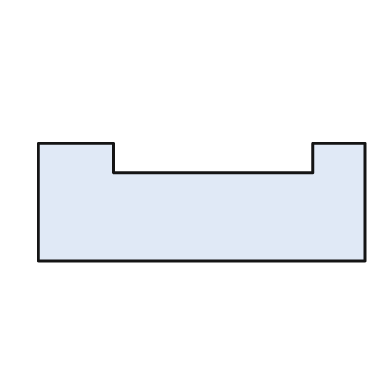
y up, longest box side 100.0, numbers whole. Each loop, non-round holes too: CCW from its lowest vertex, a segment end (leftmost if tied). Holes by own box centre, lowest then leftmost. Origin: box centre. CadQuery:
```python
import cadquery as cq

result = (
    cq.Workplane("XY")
    .moveTo(-50.0, -18.0)
    .lineTo(50.0, -18.0)
    .lineTo(50.0, 18.0)
    .lineTo(34.0, 18.0)
    .lineTo(34.0, 9.0)
    .lineTo(-27.0, 9.0)
    .lineTo(-27.0, 18.0)
    .lineTo(-50.0, 18.0)
    .close()
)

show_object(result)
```